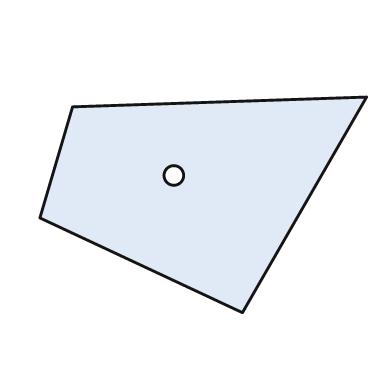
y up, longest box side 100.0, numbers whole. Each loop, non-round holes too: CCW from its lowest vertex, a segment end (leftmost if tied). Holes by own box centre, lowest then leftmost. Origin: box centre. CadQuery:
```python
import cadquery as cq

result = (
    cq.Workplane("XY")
    .moveTo(12.0, -33.0)
    .lineTo(50.0, 33.0)
    .lineTo(-40.0, 30.0)
    .lineTo(-50.0, -4.0)
    .close()
    .moveTo(-9.0, 9.0)
    .circle(3.0)
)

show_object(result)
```